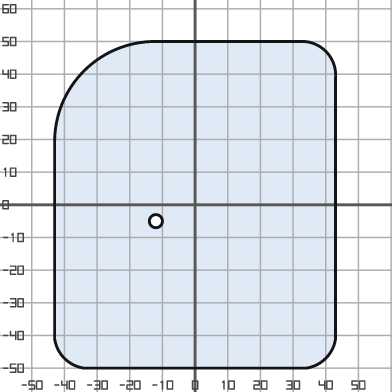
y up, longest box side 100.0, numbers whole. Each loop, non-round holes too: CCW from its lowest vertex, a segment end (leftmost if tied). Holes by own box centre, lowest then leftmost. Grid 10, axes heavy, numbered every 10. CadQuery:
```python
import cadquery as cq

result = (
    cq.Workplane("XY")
    .moveTo(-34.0, -50.0)
    .lineTo(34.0, -50.0)
    .threePointArc((40.0, -47.0), (43.0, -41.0))
    .lineTo(43.0, 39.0)
    .threePointArc((40.0, 47.0), (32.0, 50.0))
    .lineTo(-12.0, 50.0)
    .threePointArc((-34.0, 41.0), (-43.0, 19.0))
    .lineTo(-43.0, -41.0)
    .threePointArc((-40.0, -47.0), (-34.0, -50.0))
    .close()
    .moveTo(-12.0, -5.0)
    .circle(2.0)
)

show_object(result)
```